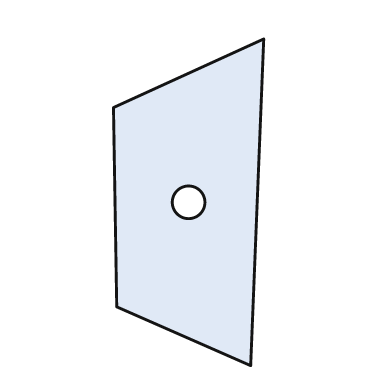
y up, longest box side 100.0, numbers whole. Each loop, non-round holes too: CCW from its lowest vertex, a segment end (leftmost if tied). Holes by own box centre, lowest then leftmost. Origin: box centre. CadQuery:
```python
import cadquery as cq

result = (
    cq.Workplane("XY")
    .moveTo(19.0, -50.0)
    .lineTo(23.0, 50.0)
    .lineTo(-23.0, 29.0)
    .lineTo(-22.0, -32.0)
    .close()
    .moveTo(0.0, 0.0)
    .circle(5.0)
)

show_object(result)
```